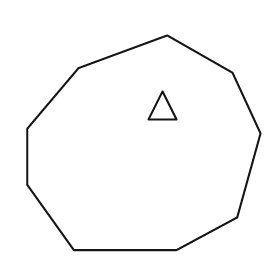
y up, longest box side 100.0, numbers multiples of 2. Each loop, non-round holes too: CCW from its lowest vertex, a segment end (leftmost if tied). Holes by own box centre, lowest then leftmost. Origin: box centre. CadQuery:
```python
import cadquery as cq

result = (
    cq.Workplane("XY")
    .moveTo(-30.0, -46.0)
    .lineTo(14.0, -46.0)
    .lineTo(40.0, -32.0)
    .lineTo(50.0, 4.0)
    .lineTo(38.0, 30.0)
    .lineTo(10.0, 46.0)
    .lineTo(-28.0, 32.0)
    .lineTo(-50.0, 6.0)
    .lineTo(-50.0, -18.0)
    .close()
    .moveTo(2.0, 10.0)
    .lineTo(14.0, 10.0)
    .lineTo(8.0, 22.0)
    .close()
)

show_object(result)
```